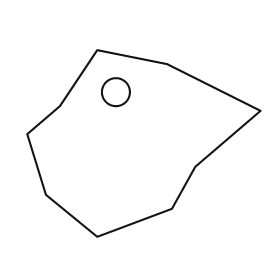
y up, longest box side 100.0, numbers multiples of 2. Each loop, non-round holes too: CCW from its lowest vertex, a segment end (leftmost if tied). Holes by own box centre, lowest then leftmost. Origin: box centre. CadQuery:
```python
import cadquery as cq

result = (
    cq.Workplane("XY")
    .moveTo(-20.0, -40.0)
    .lineTo(12.0, -28.0)
    .lineTo(22.0, -10.0)
    .lineTo(50.0, 14.0)
    .lineTo(10.0, 34.0)
    .lineTo(-20.0, 40.0)
    .lineTo(-36.0, 16.0)
    .lineTo(-50.0, 4.0)
    .lineTo(-42.0, -22.0)
    .close()
    .moveTo(-12.0, 22.0)
    .circle(6.0)
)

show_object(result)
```